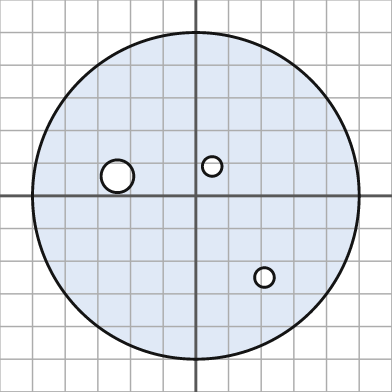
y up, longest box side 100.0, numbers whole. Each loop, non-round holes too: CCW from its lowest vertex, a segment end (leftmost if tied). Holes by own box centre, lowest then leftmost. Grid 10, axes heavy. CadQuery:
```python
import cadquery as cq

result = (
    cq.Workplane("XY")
    .moveTo(0.0, 0.0)
    .circle(50.0)
    .moveTo(21.0, -25.0)
    .circle(3.0)
    .moveTo(-24.0, 6.0)
    .circle(5.0)
    .moveTo(5.0, 9.0)
    .circle(3.0)
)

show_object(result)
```